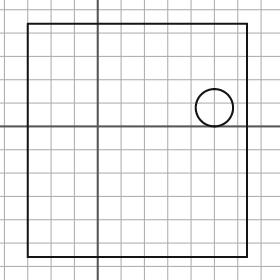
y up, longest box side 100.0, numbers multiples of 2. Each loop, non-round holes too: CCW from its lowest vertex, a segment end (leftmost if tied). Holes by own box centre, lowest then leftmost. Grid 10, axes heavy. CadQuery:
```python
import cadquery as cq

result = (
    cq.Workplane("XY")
    .moveTo(-30.0, -56.0)
    .lineTo(64.0, -56.0)
    .lineTo(64.0, 44.0)
    .lineTo(-30.0, 44.0)
    .close()
    .moveTo(50.0, 8.0)
    .circle(8.0)
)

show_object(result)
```